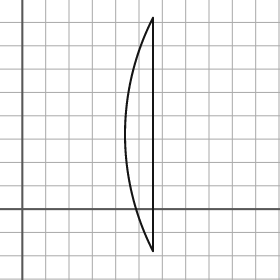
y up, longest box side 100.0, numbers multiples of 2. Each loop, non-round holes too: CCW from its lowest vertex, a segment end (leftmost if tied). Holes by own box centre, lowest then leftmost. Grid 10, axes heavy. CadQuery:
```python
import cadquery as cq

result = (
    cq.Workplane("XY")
    .moveTo(56.0, -18.0)
    .lineTo(56.0, 82.0)
    .threePointArc((44.0, 32.0), (56.0, -18.0))
    .close()
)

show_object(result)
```